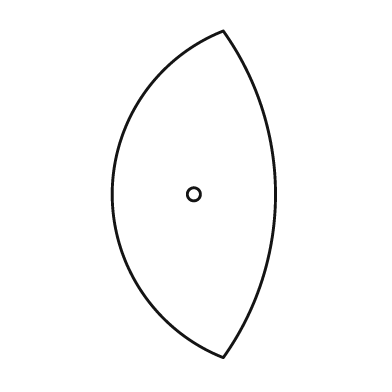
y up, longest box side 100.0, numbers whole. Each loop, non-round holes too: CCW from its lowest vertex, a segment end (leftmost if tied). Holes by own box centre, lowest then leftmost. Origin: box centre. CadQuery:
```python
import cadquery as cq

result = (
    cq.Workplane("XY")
    .moveTo(9.0, -50.0)
    .threePointArc((25.0, 0.0), (9.0, 50.0))
    .threePointArc((-25.0, 0.0), (9.0, -50.0))
    .close()
    .moveTo(0.0, 0.0)
    .circle(2.0)
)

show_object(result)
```